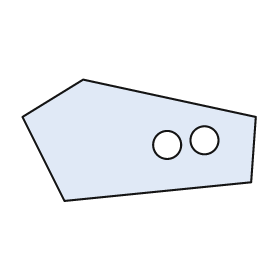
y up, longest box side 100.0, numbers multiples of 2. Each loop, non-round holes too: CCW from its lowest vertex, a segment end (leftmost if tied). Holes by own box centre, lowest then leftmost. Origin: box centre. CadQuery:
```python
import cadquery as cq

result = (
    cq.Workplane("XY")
    .moveTo(-32.0, -26.0)
    .lineTo(48.0, -18.0)
    .lineTo(50.0, 10.0)
    .lineTo(-24.0, 26.0)
    .lineTo(-50.0, 10.0)
    .close()
    .moveTo(12.0, -2.0)
    .circle(6.0)
    .moveTo(28.0, 0.0)
    .circle(6.0)
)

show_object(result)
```